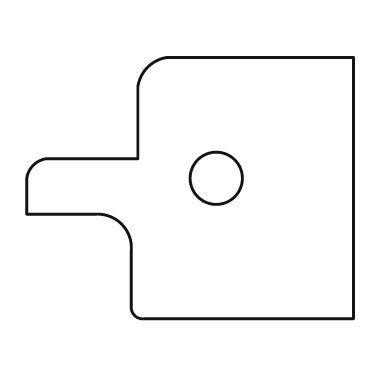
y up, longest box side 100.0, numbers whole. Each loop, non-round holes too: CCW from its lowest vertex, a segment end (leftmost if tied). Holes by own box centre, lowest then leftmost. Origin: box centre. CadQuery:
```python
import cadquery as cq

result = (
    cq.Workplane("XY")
    .moveTo(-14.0, -40.0)
    .lineTo(50.0, -40.0)
    .lineTo(50.0, 40.0)
    .lineTo(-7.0, 40.0)
    .threePointArc((-13.0, 37.0), (-16.0, 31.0))
    .lineTo(-16.0, 9.0)
    .lineTo(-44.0, 9.0)
    .threePointArc((-48.0, 7.0), (-50.0, 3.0))
    .lineTo(-50.0, -8.0)
    .lineTo(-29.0, -8.0)
    .threePointArc((-21.0, -11.0), (-18.0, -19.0))
    .lineTo(-18.0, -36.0)
    .threePointArc((-17.0, -39.0), (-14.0, -40.0))
    .close()
    .moveTo(8.0, 3.0)
    .circle(8.0)
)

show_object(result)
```